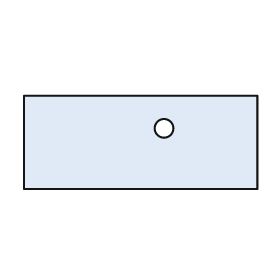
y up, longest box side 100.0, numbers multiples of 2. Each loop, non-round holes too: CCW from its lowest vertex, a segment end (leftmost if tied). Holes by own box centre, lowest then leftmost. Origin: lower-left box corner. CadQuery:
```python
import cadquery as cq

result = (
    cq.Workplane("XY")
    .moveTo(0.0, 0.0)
    .lineTo(100.0, 0.0)
    .lineTo(100.0, 40.0)
    .lineTo(0.0, 40.0)
    .close()
    .moveTo(60.0, 26.0)
    .circle(4.0)
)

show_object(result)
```